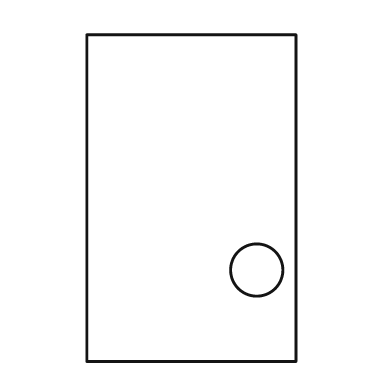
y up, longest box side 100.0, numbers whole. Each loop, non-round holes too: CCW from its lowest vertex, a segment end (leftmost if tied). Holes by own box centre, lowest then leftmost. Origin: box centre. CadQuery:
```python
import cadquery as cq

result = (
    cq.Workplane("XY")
    .moveTo(-32.0, -50.0)
    .lineTo(32.0, -50.0)
    .lineTo(32.0, 50.0)
    .lineTo(-32.0, 50.0)
    .close()
    .moveTo(20.0, -22.0)
    .circle(8.0)
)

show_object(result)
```